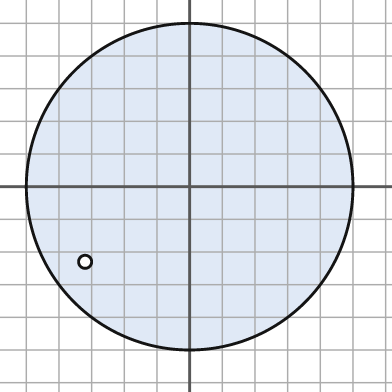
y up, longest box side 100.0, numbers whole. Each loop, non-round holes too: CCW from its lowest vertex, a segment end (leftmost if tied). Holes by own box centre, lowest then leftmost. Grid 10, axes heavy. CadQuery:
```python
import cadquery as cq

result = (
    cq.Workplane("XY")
    .moveTo(0.0, 0.0)
    .circle(50.0)
    .moveTo(-32.0, -23.0)
    .circle(2.0)
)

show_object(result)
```